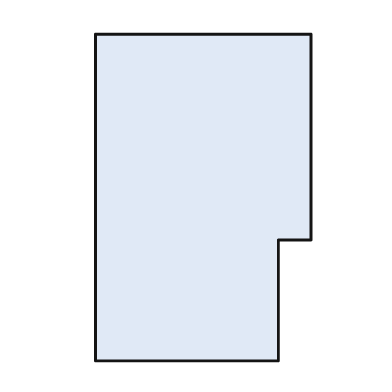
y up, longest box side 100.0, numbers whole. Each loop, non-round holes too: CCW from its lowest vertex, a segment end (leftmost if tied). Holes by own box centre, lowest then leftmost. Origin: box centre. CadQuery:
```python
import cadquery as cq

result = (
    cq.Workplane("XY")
    .moveTo(-33.0, -50.0)
    .lineTo(23.0, -50.0)
    .lineTo(23.0, -13.0)
    .lineTo(33.0, -13.0)
    .lineTo(33.0, 50.0)
    .lineTo(-33.0, 50.0)
    .close()
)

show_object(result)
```